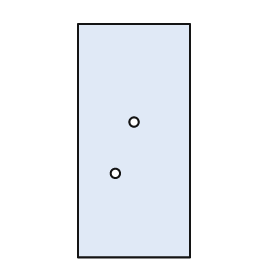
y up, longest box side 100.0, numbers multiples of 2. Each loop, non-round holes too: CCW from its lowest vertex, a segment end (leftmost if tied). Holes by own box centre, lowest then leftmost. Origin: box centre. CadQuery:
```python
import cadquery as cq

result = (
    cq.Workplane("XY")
    .moveTo(-24.0, -50.0)
    .lineTo(24.0, -50.0)
    .lineTo(24.0, 50.0)
    .lineTo(-24.0, 50.0)
    .close()
    .moveTo(-8.0, -14.0)
    .circle(2.0)
    .moveTo(0.0, 8.0)
    .circle(2.0)
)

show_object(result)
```